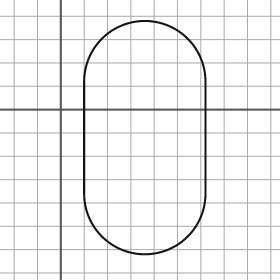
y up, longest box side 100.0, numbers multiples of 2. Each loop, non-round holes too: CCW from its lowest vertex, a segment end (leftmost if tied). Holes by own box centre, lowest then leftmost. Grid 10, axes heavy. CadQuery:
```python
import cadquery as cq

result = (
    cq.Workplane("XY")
    .moveTo(10.0, -36.0)
    .threePointArc((36.0, -62.0), (62.0, -36.0))
    .lineTo(62.0, 12.0)
    .threePointArc((36.0, 38.0), (10.0, 12.0))
    .close()
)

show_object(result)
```